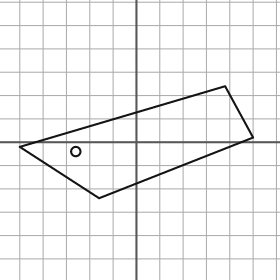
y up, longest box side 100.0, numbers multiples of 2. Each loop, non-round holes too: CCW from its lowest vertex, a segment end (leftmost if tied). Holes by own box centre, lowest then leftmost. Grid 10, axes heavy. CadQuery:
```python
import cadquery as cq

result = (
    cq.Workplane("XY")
    .moveTo(-16.0, -24.0)
    .lineTo(50.0, 2.0)
    .lineTo(38.0, 24.0)
    .lineTo(-50.0, -2.0)
    .close()
    .moveTo(-26.0, -4.0)
    .circle(2.0)
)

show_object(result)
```